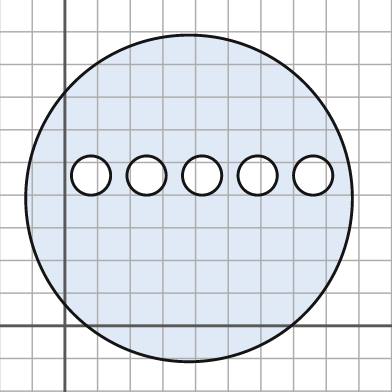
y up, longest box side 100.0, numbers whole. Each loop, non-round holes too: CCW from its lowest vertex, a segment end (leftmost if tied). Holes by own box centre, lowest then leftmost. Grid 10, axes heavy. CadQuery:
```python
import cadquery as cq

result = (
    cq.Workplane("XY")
    .moveTo(38.0, 39.0)
    .circle(50.0)
    .moveTo(8.0, 46.0)
    .circle(6.0)
    .moveTo(25.0, 46.0)
    .circle(6.0)
    .moveTo(42.0, 46.0)
    .circle(6.0)
    .moveTo(59.0, 46.0)
    .circle(6.0)
    .moveTo(76.0, 46.0)
    .circle(6.0)
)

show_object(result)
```